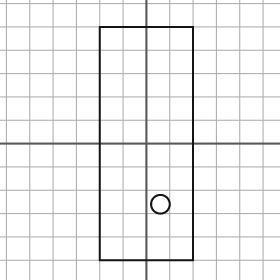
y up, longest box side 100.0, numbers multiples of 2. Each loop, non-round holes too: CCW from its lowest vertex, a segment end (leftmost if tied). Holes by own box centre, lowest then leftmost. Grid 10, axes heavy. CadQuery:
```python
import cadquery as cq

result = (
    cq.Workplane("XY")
    .moveTo(-20.0, -50.0)
    .lineTo(20.0, -50.0)
    .lineTo(20.0, 50.0)
    .lineTo(-20.0, 50.0)
    .close()
    .moveTo(6.0, -26.0)
    .circle(4.0)
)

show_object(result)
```